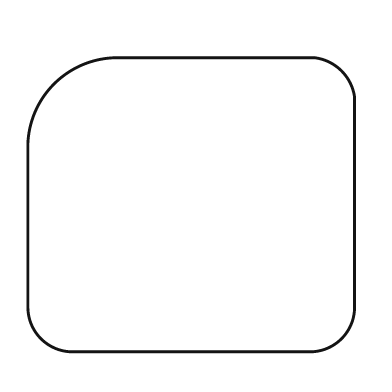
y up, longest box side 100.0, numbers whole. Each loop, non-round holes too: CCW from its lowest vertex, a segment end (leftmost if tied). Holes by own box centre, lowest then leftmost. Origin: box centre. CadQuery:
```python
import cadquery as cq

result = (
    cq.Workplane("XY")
    .moveTo(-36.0, -45.0)
    .lineTo(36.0, -45.0)
    .threePointArc((46.0, -41.0), (50.0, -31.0))
    .lineTo(50.0, 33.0)
    .threePointArc((46.0, 41.0), (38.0, 45.0))
    .lineTo(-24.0, 45.0)
    .threePointArc((-42.0, 37.0), (-50.0, 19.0))
    .lineTo(-50.0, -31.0)
    .threePointArc((-46.0, -41.0), (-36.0, -45.0))
    .close()
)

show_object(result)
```